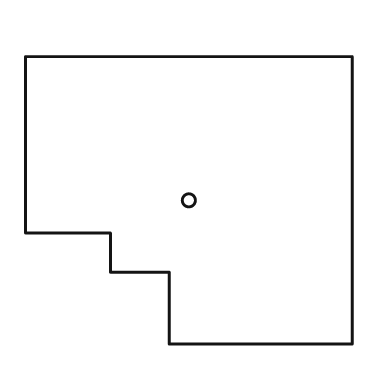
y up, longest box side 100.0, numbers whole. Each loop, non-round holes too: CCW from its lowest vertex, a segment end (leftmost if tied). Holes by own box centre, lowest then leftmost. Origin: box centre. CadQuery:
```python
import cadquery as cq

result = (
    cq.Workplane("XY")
    .moveTo(-6.0, -44.0)
    .lineTo(50.0, -44.0)
    .lineTo(50.0, 44.0)
    .lineTo(-50.0, 44.0)
    .lineTo(-50.0, -10.0)
    .lineTo(-24.0, -10.0)
    .lineTo(-24.0, -22.0)
    .lineTo(-6.0, -22.0)
    .close()
    .moveTo(0.0, 0.0)
    .circle(2.0)
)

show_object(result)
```